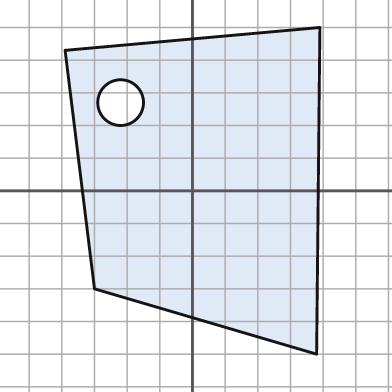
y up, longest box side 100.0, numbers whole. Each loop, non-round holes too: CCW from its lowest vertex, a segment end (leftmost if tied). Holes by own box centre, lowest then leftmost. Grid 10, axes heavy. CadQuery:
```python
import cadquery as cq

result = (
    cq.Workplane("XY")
    .moveTo(38.0, -50.0)
    .lineTo(39.0, 50.0)
    .lineTo(-39.0, 43.0)
    .lineTo(-30.0, -30.0)
    .close()
    .moveTo(-22.0, 27.0)
    .circle(7.0)
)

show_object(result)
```